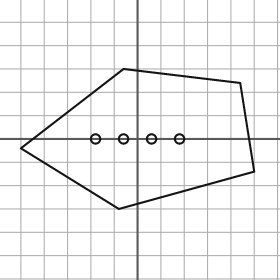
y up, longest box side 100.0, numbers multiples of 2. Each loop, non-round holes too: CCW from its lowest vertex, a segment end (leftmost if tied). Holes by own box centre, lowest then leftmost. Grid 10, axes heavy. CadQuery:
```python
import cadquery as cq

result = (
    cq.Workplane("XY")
    .moveTo(-8.0, -30.0)
    .lineTo(50.0, -14.0)
    .lineTo(44.0, 24.0)
    .lineTo(-6.0, 30.0)
    .lineTo(-50.0, -4.0)
    .close()
    .moveTo(-18.0, 0.0)
    .circle(2.0)
    .moveTo(-6.0, 0.0)
    .circle(2.0)
    .moveTo(6.0, 0.0)
    .circle(2.0)
    .moveTo(18.0, 0.0)
    .circle(2.0)
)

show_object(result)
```